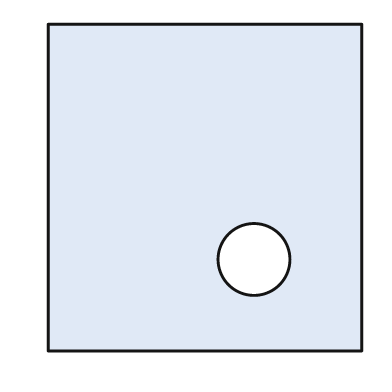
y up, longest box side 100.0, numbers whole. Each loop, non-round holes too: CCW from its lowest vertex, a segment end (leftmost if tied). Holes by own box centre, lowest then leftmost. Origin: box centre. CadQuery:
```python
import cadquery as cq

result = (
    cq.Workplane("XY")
    .moveTo(-48.0, -50.0)
    .lineTo(48.0, -50.0)
    .lineTo(48.0, 50.0)
    .lineTo(-48.0, 50.0)
    .close()
    .moveTo(15.0, -22.0)
    .circle(11.0)
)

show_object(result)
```